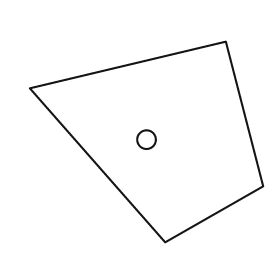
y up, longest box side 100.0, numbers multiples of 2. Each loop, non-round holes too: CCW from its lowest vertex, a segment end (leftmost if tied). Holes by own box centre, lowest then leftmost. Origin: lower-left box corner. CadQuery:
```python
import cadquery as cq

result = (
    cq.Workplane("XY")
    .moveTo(58.0, 0.0)
    .lineTo(100.0, 24.0)
    .lineTo(84.0, 86.0)
    .lineTo(0.0, 66.0)
    .close()
    .moveTo(50.0, 44.0)
    .circle(4.0)
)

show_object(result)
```